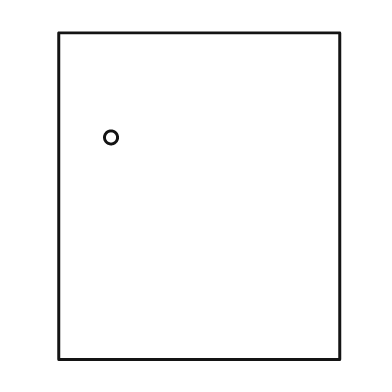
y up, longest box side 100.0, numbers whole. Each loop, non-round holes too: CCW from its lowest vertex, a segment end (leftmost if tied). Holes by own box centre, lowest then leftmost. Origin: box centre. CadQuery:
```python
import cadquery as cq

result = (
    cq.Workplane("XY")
    .moveTo(-43.0, -50.0)
    .lineTo(43.0, -50.0)
    .lineTo(43.0, 50.0)
    .lineTo(-43.0, 50.0)
    .close()
    .moveTo(-27.0, 18.0)
    .circle(2.0)
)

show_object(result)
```